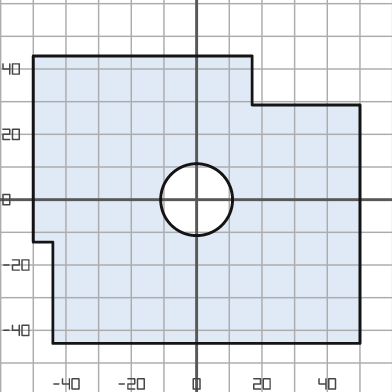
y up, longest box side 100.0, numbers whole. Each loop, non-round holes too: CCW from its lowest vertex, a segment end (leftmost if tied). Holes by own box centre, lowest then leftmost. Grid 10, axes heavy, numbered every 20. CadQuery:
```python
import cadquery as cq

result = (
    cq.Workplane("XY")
    .moveTo(-44.0, -44.0)
    .lineTo(50.0, -44.0)
    .lineTo(50.0, 29.0)
    .lineTo(17.0, 29.0)
    .lineTo(17.0, 44.0)
    .lineTo(-50.0, 44.0)
    .lineTo(-50.0, -13.0)
    .lineTo(-44.0, -13.0)
    .close()
    .moveTo(0.0, 0.0)
    .circle(11.0)
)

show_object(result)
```